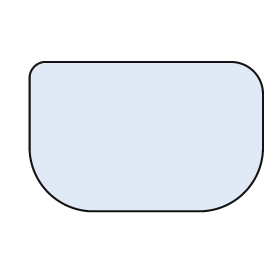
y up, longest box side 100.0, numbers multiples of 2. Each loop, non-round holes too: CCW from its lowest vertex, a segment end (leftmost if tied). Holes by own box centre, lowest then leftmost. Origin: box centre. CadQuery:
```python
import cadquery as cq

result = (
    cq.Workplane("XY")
    .moveTo(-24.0, -32.0)
    .lineTo(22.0, -32.0)
    .threePointArc((42.0, -24.0), (50.0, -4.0))
    .lineTo(50.0, 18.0)
    .threePointArc((46.0, 28.0), (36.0, 32.0))
    .lineTo(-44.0, 32.0)
    .threePointArc((-48.0, 30.0), (-50.0, 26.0))
    .lineTo(-50.0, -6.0)
    .threePointArc((-42.0, -24.0), (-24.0, -32.0))
    .close()
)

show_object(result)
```